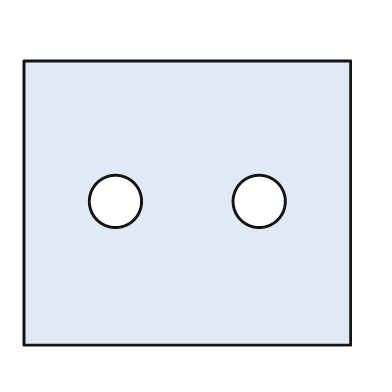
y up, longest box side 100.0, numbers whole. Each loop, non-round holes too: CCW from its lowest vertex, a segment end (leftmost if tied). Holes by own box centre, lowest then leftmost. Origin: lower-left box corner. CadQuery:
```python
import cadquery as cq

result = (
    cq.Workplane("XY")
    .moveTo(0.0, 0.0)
    .lineTo(100.0, 0.0)
    .lineTo(100.0, 87.0)
    .lineTo(0.0, 87.0)
    .close()
    .moveTo(28.0, 44.0)
    .circle(8.0)
    .moveTo(72.0, 44.0)
    .circle(8.0)
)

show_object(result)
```